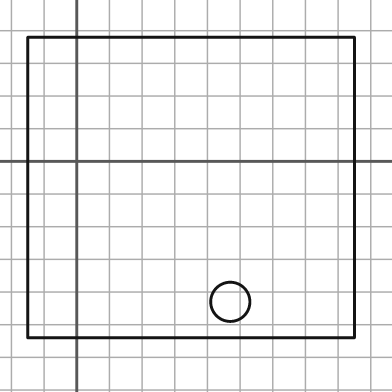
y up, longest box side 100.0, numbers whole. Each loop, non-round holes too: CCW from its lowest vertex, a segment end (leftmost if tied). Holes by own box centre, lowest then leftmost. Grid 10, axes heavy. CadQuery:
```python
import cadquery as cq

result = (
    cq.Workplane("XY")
    .moveTo(-15.0, -54.0)
    .lineTo(85.0, -54.0)
    .lineTo(85.0, 38.0)
    .lineTo(-15.0, 38.0)
    .close()
    .moveTo(47.0, -43.0)
    .circle(6.0)
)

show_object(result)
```